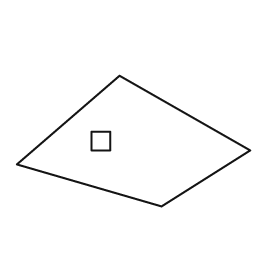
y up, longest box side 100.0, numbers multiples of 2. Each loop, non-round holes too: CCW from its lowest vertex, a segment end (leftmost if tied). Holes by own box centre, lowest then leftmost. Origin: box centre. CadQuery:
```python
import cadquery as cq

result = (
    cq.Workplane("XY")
    .moveTo(12.0, -28.0)
    .lineTo(50.0, -4.0)
    .lineTo(-6.0, 28.0)
    .lineTo(-50.0, -10.0)
    .close()
    .moveTo(-18.0, -4.0)
    .lineTo(-10.0, -4.0)
    .lineTo(-10.0, 4.0)
    .lineTo(-18.0, 4.0)
    .close()
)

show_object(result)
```